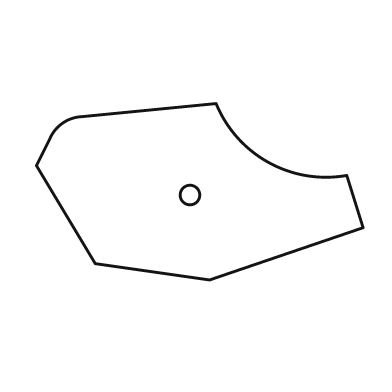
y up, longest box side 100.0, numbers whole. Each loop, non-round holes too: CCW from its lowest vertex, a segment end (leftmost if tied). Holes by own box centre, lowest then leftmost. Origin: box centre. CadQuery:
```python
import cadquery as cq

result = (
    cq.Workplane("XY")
    .moveTo(3.0, -27.0)
    .lineTo(50.0, -11.0)
    .lineTo(45.0, 5.0)
    .threePointArc((21.0, 9.0), (5.0, 27.0))
    .lineTo(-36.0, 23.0)
    .threePointArc((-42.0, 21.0), (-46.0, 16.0))
    .lineTo(-50.0, 8.0)
    .lineTo(-32.0, -22.0)
    .close()
    .moveTo(-3.0, -1.0)
    .circle(3.0)
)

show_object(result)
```